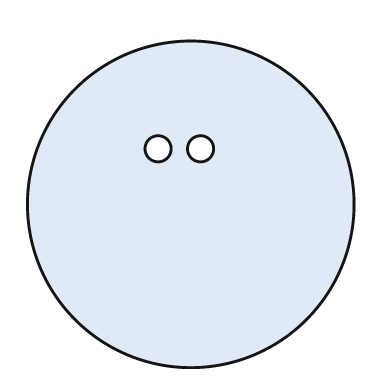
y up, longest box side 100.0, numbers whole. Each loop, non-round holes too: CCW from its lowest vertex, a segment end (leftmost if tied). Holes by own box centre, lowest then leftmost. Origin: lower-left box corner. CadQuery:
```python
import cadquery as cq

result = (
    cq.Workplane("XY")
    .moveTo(50.0, 50.0)
    .circle(50.0)
    .moveTo(40.0, 67.0)
    .circle(4.0)
    .moveTo(53.0, 67.0)
    .circle(4.0)
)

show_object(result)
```